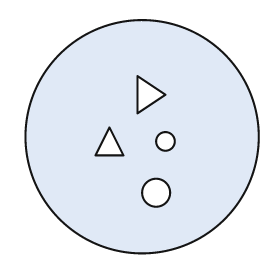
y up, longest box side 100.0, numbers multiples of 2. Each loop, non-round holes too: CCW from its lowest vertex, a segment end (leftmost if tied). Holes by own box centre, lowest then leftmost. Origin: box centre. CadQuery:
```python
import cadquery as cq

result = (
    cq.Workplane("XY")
    .moveTo(0.0, 0.0)
    .circle(50.0)
    .moveTo(6.0, -24.0)
    .circle(6.0)
    .moveTo(-20.0, -8.0)
    .lineTo(-8.0, -8.0)
    .lineTo(-14.0, 4.0)
    .close()
    .moveTo(10.0, -2.0)
    .circle(4.0)
    .moveTo(-2.0, 10.0)
    .lineTo(10.0, 18.0)
    .lineTo(-2.0, 26.0)
    .close()
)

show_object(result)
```